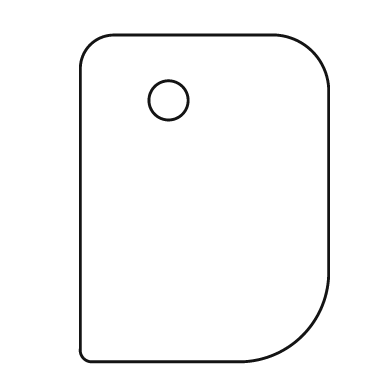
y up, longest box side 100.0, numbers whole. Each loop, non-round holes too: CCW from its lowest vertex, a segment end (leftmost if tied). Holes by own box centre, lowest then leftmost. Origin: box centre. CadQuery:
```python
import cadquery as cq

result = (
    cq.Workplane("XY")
    .moveTo(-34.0, -50.0)
    .lineTo(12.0, -50.0)
    .threePointArc((30.0, -42.0), (38.0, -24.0))
    .lineTo(38.0, 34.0)
    .threePointArc((33.0, 45.0), (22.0, 50.0))
    .lineTo(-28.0, 50.0)
    .threePointArc((-35.0, 47.0), (-38.0, 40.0))
    .lineTo(-38.0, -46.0)
    .threePointArc((-37.0, -49.0), (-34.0, -50.0))
    .close()
    .moveTo(-11.0, 30.0)
    .circle(6.0)
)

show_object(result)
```